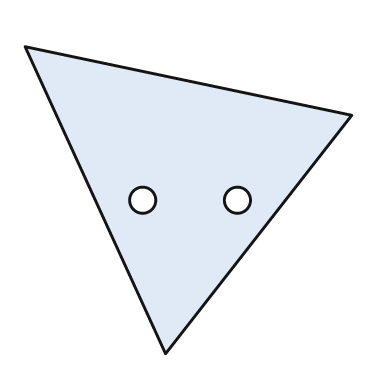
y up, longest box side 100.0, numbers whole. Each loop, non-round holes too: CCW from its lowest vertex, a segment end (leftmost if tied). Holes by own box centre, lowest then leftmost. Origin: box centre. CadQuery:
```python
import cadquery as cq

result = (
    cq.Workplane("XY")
    .moveTo(-7.0, -47.0)
    .lineTo(50.0, 26.0)
    .lineTo(-50.0, 47.0)
    .close()
    .moveTo(-14.0, 0.0)
    .circle(4.0)
    .moveTo(15.0, 0.0)
    .circle(4.0)
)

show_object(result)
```